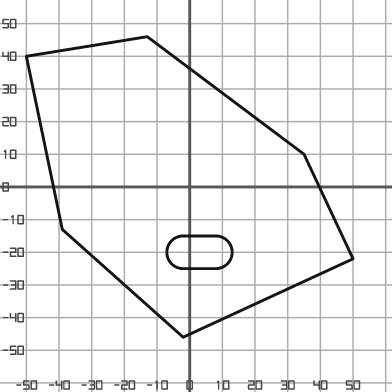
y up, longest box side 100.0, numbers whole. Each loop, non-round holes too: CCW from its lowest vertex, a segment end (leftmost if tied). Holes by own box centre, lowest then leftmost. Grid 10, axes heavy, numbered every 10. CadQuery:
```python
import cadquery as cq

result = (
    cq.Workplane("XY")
    .moveTo(-2.0, -46.0)
    .lineTo(50.0, -22.0)
    .lineTo(35.0, 10.0)
    .lineTo(-13.0, 46.0)
    .lineTo(-50.0, 40.0)
    .lineTo(-39.0, -13.0)
    .close()
    .moveTo(-2.0, -25.0)
    .lineTo(8.0, -25.0)
    .threePointArc((13.0, -20.0), (8.0, -15.0))
    .lineTo(-2.0, -15.0)
    .threePointArc((-7.0, -20.0), (-2.0, -25.0))
    .close()
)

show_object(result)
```